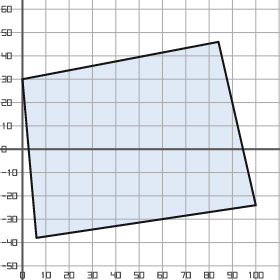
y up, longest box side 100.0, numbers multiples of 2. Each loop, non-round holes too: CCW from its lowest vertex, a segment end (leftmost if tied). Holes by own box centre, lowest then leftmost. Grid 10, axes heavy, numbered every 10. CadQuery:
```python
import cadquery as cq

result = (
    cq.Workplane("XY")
    .moveTo(6.0, -38.0)
    .lineTo(100.0, -24.0)
    .lineTo(84.0, 46.0)
    .lineTo(0.0, 30.0)
    .close()
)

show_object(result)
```